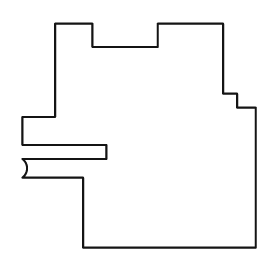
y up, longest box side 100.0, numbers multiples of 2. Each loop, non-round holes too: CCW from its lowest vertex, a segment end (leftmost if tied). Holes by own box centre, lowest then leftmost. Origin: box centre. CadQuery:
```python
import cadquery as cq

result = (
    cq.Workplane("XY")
    .moveTo(-24.0, -48.0)
    .lineTo(50.0, -48.0)
    .lineTo(50.0, 12.0)
    .lineTo(42.0, 12.0)
    .lineTo(42.0, 18.0)
    .lineTo(36.0, 18.0)
    .lineTo(36.0, 48.0)
    .lineTo(8.0, 48.0)
    .lineTo(8.0, 38.0)
    .lineTo(-20.0, 38.0)
    .lineTo(-20.0, 48.0)
    .lineTo(-36.0, 48.0)
    .lineTo(-36.0, 8.0)
    .lineTo(-50.0, 8.0)
    .lineTo(-50.0, -4.0)
    .lineTo(-14.0, -4.0)
    .lineTo(-14.0, -10.0)
    .lineTo(-50.0, -10.0)
    .threePointArc((-48.0, -14.0), (-50.0, -18.0))
    .lineTo(-24.0, -18.0)
    .close()
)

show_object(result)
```